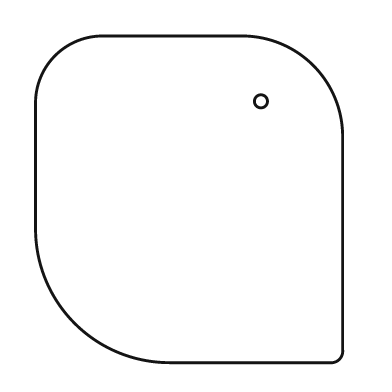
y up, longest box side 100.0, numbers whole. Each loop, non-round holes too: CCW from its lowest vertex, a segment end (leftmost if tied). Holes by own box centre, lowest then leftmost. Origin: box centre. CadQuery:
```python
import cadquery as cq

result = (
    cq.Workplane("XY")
    .moveTo(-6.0, -50.0)
    .lineTo(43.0, -50.0)
    .threePointArc((46.0, -49.0), (47.0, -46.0))
    .lineTo(47.0, 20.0)
    .threePointArc((38.0, 41.0), (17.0, 50.0))
    .lineTo(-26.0, 50.0)
    .threePointArc((-41.0, 44.0), (-47.0, 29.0))
    .lineTo(-47.0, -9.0)
    .threePointArc((-35.0, -38.0), (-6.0, -50.0))
    .close()
    .moveTo(22.0, 30.0)
    .circle(2.0)
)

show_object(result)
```